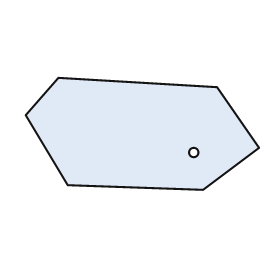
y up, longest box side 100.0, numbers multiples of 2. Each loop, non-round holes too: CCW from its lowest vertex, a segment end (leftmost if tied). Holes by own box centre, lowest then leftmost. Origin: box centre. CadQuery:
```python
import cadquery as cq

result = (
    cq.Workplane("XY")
    .moveTo(26.0, -24.0)
    .lineTo(50.0, -6.0)
    .lineTo(32.0, 20.0)
    .lineTo(-36.0, 24.0)
    .lineTo(-50.0, 8.0)
    .lineTo(-32.0, -22.0)
    .close()
    .moveTo(22.0, -8.0)
    .circle(2.0)
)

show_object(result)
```